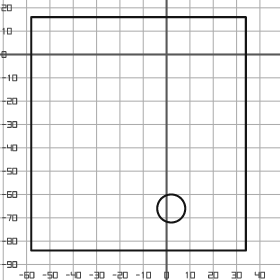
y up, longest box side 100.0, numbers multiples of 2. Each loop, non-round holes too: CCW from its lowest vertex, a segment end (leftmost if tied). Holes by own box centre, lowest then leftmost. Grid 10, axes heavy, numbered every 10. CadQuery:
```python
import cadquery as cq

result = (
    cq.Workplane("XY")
    .moveTo(-58.0, -84.0)
    .lineTo(34.0, -84.0)
    .lineTo(34.0, 16.0)
    .lineTo(-58.0, 16.0)
    .close()
    .moveTo(2.0, -66.0)
    .circle(6.0)
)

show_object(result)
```